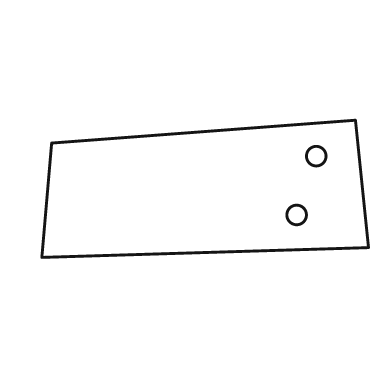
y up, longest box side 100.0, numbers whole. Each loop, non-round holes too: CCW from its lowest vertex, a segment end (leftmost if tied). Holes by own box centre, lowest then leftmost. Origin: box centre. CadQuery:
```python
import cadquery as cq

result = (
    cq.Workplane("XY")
    .moveTo(-50.0, -21.0)
    .lineTo(50.0, -18.0)
    .lineTo(46.0, 21.0)
    .lineTo(-47.0, 14.0)
    .close()
    .moveTo(28.0, -8.0)
    .circle(3.0)
    .moveTo(34.0, 10.0)
    .circle(3.0)
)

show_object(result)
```